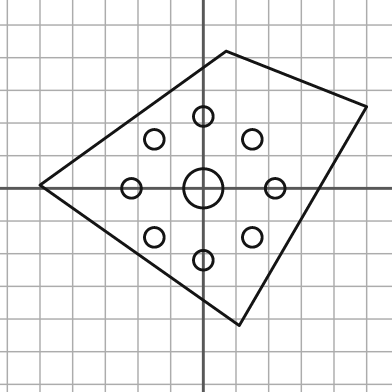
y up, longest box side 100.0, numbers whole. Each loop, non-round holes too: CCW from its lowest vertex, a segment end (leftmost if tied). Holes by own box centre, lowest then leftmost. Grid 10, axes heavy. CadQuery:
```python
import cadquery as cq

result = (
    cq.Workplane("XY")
    .moveTo(11.0, -42.0)
    .lineTo(50.0, 25.0)
    .lineTo(7.0, 42.0)
    .lineTo(-50.0, 1.0)
    .close()
    .moveTo(0.0, -22.0)
    .circle(3.0)
    .moveTo(-15.0, -15.0)
    .circle(3.0)
    .moveTo(15.0, -15.0)
    .circle(3.0)
    .moveTo(-22.0, 0.0)
    .circle(3.0)
    .moveTo(0.0, 0.0)
    .circle(6.0)
    .moveTo(22.0, 0.0)
    .circle(3.0)
    .moveTo(-15.0, 15.0)
    .circle(3.0)
    .moveTo(15.0, 15.0)
    .circle(3.0)
    .moveTo(0.0, 22.0)
    .circle(3.0)
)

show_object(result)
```